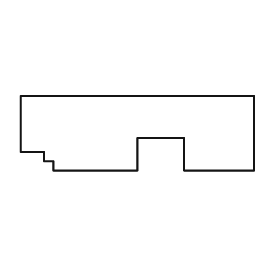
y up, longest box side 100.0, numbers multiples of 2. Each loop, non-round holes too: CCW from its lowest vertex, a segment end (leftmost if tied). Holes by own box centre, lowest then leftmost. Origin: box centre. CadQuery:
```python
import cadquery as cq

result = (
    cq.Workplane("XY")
    .moveTo(-36.0, -16.0)
    .lineTo(0.0, -16.0)
    .lineTo(0.0, -2.0)
    .lineTo(20.0, -2.0)
    .lineTo(20.0, -16.0)
    .lineTo(50.0, -16.0)
    .lineTo(50.0, 16.0)
    .lineTo(-50.0, 16.0)
    .lineTo(-50.0, -8.0)
    .lineTo(-40.0, -8.0)
    .lineTo(-40.0, -12.0)
    .lineTo(-36.0, -12.0)
    .close()
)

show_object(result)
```